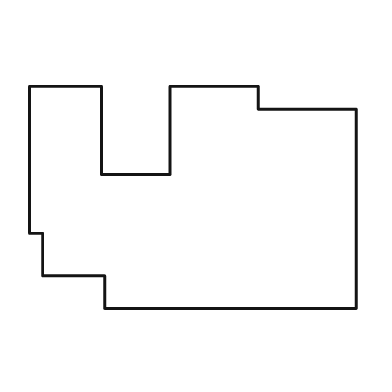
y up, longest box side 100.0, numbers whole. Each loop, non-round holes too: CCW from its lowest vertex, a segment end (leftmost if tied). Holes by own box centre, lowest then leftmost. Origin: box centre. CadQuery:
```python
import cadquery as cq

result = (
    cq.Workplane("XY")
    .moveTo(-27.0, -34.0)
    .lineTo(50.0, -34.0)
    .lineTo(50.0, 27.0)
    .lineTo(20.0, 27.0)
    .lineTo(20.0, 34.0)
    .lineTo(-7.0, 34.0)
    .lineTo(-7.0, 7.0)
    .lineTo(-28.0, 7.0)
    .lineTo(-28.0, 34.0)
    .lineTo(-50.0, 34.0)
    .lineTo(-50.0, -11.0)
    .lineTo(-46.0, -11.0)
    .lineTo(-46.0, -24.0)
    .lineTo(-27.0, -24.0)
    .close()
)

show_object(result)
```